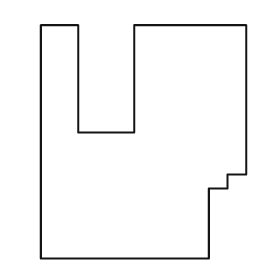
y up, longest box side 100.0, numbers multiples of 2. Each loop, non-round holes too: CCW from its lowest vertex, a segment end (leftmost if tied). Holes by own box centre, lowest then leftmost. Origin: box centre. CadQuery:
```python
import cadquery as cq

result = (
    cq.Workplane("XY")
    .moveTo(-44.0, -50.0)
    .lineTo(28.0, -50.0)
    .lineTo(28.0, -20.0)
    .lineTo(36.0, -20.0)
    .lineTo(36.0, -14.0)
    .lineTo(44.0, -14.0)
    .lineTo(44.0, 50.0)
    .lineTo(-4.0, 50.0)
    .lineTo(-4.0, 4.0)
    .lineTo(-28.0, 4.0)
    .lineTo(-28.0, 50.0)
    .lineTo(-44.0, 50.0)
    .close()
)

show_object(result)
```